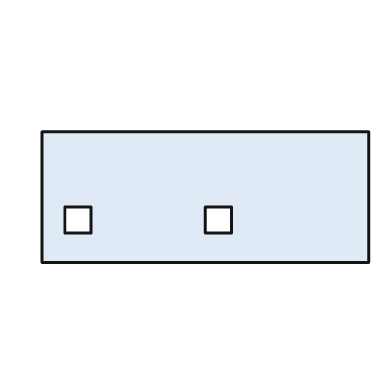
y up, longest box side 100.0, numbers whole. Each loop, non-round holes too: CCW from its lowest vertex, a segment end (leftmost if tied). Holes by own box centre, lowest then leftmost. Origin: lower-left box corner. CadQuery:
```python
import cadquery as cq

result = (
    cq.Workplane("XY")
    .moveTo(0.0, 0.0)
    .lineTo(100.0, 0.0)
    .lineTo(100.0, 40.0)
    .lineTo(0.0, 40.0)
    .close()
    .moveTo(7.0, 9.0)
    .lineTo(15.0, 9.0)
    .lineTo(15.0, 17.0)
    .lineTo(7.0, 17.0)
    .close()
    .moveTo(50.0, 9.0)
    .lineTo(58.0, 9.0)
    .lineTo(58.0, 17.0)
    .lineTo(50.0, 17.0)
    .close()
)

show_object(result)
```